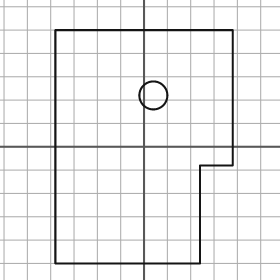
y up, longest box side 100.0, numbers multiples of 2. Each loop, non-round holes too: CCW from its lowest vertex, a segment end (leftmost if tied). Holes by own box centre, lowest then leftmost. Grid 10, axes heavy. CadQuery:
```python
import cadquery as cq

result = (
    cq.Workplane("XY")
    .moveTo(-38.0, -50.0)
    .lineTo(24.0, -50.0)
    .lineTo(24.0, -8.0)
    .lineTo(38.0, -8.0)
    .lineTo(38.0, 50.0)
    .lineTo(-38.0, 50.0)
    .close()
    .moveTo(4.0, 22.0)
    .circle(6.0)
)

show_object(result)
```